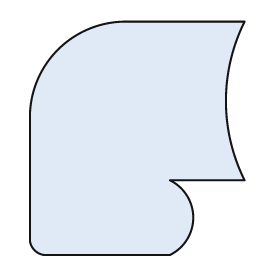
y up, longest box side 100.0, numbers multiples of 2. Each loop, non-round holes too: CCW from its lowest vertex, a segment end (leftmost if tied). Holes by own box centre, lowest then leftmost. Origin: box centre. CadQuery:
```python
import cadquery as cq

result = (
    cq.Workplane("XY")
    .moveTo(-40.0, -50.0)
    .lineTo(14.0, -50.0)
    .threePointArc((24.0, -34.0), (14.0, -18.0))
    .lineTo(46.0, -18.0)
    .threePointArc((38.0, 16.0), (46.0, 50.0))
    .lineTo(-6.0, 50.0)
    .threePointArc((-34.0, 38.0), (-46.0, 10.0))
    .lineTo(-46.0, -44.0)
    .threePointArc((-44.0, -48.0), (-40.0, -50.0))
    .close()
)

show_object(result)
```